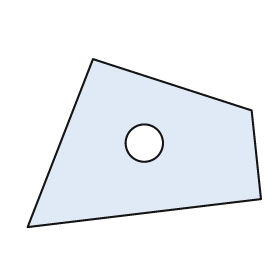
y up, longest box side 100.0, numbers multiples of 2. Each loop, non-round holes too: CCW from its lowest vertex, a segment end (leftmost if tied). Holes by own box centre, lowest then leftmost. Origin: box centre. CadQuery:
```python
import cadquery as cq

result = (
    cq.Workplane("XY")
    .moveTo(-50.0, -36.0)
    .lineTo(50.0, -24.0)
    .lineTo(46.0, 14.0)
    .lineTo(-22.0, 36.0)
    .close()
    .moveTo(0.0, 0.0)
    .circle(8.0)
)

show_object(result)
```